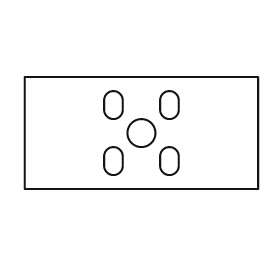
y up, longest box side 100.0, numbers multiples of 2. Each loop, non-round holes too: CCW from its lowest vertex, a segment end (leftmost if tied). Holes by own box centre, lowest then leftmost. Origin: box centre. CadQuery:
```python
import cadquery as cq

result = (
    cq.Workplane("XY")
    .moveTo(-50.0, -24.0)
    .lineTo(50.0, -24.0)
    .lineTo(50.0, 24.0)
    .lineTo(-50.0, 24.0)
    .close()
    .moveTo(-16.0, -14.0)
    .threePointArc((-12.0, -18.0), (-8.0, -14.0))
    .lineTo(-8.0, -10.0)
    .threePointArc((-12.0, -6.0), (-16.0, -10.0))
    .close()
    .moveTo(8.0, -14.0)
    .threePointArc((12.0, -18.0), (16.0, -14.0))
    .lineTo(16.0, -10.0)
    .threePointArc((12.0, -6.0), (8.0, -10.0))
    .close()
    .moveTo(0.0, 0.0)
    .circle(6.0)
    .moveTo(-16.0, 10.0)
    .threePointArc((-12.0, 6.0), (-8.0, 10.0))
    .lineTo(-8.0, 14.0)
    .threePointArc((-12.0, 18.0), (-16.0, 14.0))
    .close()
    .moveTo(8.0, 10.0)
    .threePointArc((12.0, 6.0), (16.0, 10.0))
    .lineTo(16.0, 14.0)
    .threePointArc((12.0, 18.0), (8.0, 14.0))
    .close()
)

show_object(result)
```